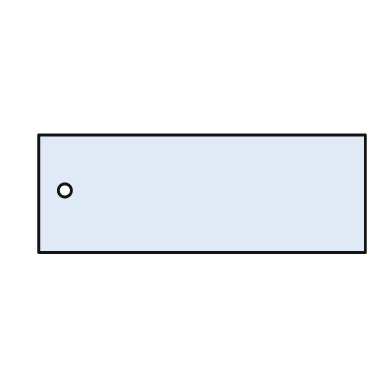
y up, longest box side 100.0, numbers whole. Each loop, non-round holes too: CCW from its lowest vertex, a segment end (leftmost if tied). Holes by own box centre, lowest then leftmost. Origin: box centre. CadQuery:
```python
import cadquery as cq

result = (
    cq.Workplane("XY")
    .moveTo(-50.0, -18.0)
    .lineTo(50.0, -18.0)
    .lineTo(50.0, 18.0)
    .lineTo(-50.0, 18.0)
    .close()
    .moveTo(-42.0, 1.0)
    .circle(2.0)
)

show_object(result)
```